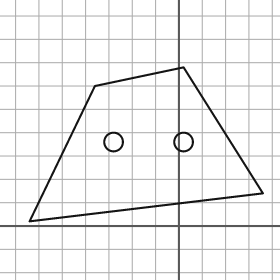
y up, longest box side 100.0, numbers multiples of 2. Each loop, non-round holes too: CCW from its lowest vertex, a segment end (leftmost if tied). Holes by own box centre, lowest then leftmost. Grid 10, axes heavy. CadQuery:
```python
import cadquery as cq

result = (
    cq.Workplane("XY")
    .moveTo(-64.0, 2.0)
    .lineTo(36.0, 14.0)
    .lineTo(2.0, 68.0)
    .lineTo(-36.0, 60.0)
    .close()
    .moveTo(-28.0, 36.0)
    .circle(4.0)
    .moveTo(2.0, 36.0)
    .circle(4.0)
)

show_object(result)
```